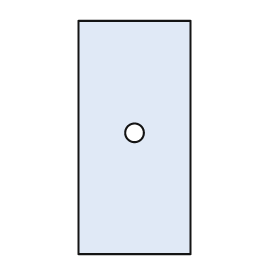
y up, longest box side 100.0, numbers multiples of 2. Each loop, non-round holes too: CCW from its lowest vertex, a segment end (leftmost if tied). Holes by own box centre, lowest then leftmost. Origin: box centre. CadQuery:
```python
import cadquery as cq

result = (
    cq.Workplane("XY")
    .moveTo(-24.0, -50.0)
    .lineTo(24.0, -50.0)
    .lineTo(24.0, 50.0)
    .lineTo(-24.0, 50.0)
    .close()
    .moveTo(0.0, 2.0)
    .circle(4.0)
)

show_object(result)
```